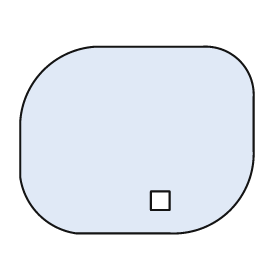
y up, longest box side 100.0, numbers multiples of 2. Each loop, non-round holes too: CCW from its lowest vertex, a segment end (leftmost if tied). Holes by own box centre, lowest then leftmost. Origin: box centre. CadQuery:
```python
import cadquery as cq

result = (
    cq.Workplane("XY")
    .moveTo(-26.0, -40.0)
    .lineTo(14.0, -40.0)
    .threePointArc((40.0, -30.0), (50.0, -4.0))
    .lineTo(50.0, 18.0)
    .threePointArc((44.0, 34.0), (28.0, 40.0))
    .lineTo(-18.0, 40.0)
    .threePointArc((-40.0, 30.0), (-50.0, 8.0))
    .lineTo(-50.0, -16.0)
    .threePointArc((-42.0, -32.0), (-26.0, -40.0))
    .close()
    .moveTo(6.0, -30.0)
    .lineTo(14.0, -30.0)
    .lineTo(14.0, -22.0)
    .lineTo(6.0, -22.0)
    .close()
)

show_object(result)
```